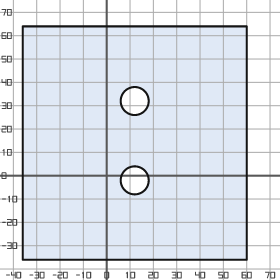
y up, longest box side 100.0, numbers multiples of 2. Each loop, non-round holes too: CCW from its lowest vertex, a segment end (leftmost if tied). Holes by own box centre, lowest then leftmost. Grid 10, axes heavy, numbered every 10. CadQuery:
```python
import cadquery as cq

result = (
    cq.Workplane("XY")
    .moveTo(-36.0, -36.0)
    .lineTo(60.0, -36.0)
    .lineTo(60.0, 64.0)
    .lineTo(-36.0, 64.0)
    .close()
    .moveTo(12.0, -2.0)
    .circle(6.0)
    .moveTo(12.0, 32.0)
    .circle(6.0)
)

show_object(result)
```